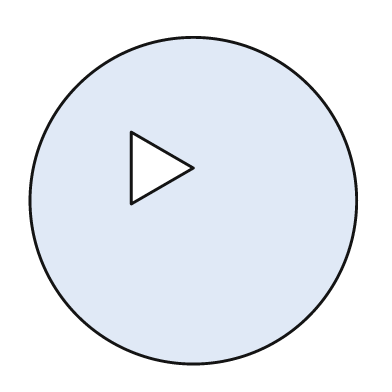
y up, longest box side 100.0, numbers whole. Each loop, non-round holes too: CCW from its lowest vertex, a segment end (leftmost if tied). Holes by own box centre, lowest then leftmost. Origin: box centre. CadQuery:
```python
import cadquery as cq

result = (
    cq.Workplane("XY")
    .moveTo(0.0, 0.0)
    .circle(50.0)
    .moveTo(-19.0, -1.0)
    .lineTo(0.0, 10.0)
    .lineTo(-19.0, 21.0)
    .close()
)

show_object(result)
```